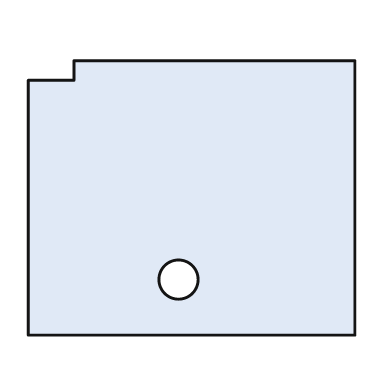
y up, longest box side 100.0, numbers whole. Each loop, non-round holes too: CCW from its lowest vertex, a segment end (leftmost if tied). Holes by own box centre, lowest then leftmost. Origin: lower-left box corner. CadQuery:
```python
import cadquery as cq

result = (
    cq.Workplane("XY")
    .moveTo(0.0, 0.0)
    .lineTo(100.0, 0.0)
    .lineTo(100.0, 84.0)
    .lineTo(14.0, 84.0)
    .lineTo(14.0, 78.0)
    .lineTo(0.0, 78.0)
    .close()
    .moveTo(46.0, 17.0)
    .circle(6.0)
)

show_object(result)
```